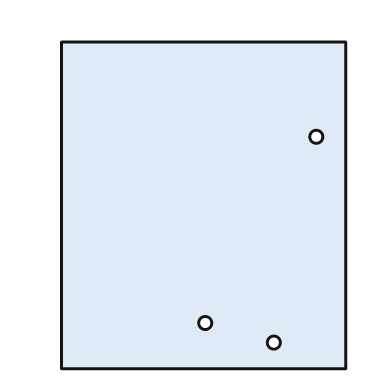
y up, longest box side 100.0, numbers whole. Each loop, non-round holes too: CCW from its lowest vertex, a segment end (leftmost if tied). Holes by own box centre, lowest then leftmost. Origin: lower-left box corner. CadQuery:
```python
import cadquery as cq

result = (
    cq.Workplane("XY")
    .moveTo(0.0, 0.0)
    .lineTo(87.0, 0.0)
    .lineTo(87.0, 100.0)
    .lineTo(0.0, 100.0)
    .close()
    .moveTo(65.0, 8.0)
    .circle(2.0)
    .moveTo(44.0, 14.0)
    .circle(2.0)
    .moveTo(78.0, 71.0)
    .circle(2.0)
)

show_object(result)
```